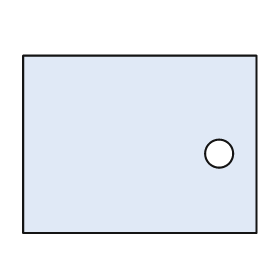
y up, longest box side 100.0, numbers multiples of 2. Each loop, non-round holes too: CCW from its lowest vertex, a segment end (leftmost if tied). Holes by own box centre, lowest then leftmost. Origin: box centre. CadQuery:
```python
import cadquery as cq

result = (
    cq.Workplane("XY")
    .moveTo(-50.0, -38.0)
    .lineTo(50.0, -38.0)
    .lineTo(50.0, 38.0)
    .lineTo(-50.0, 38.0)
    .close()
    .moveTo(34.0, -4.0)
    .circle(6.0)
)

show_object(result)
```